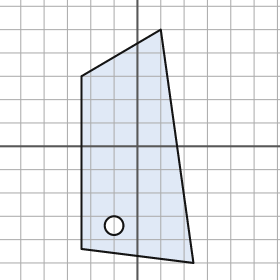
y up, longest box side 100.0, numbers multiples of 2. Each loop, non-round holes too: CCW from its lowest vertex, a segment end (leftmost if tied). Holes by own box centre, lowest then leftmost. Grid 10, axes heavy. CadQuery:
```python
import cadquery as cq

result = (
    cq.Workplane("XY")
    .moveTo(24.0, -50.0)
    .lineTo(10.0, 50.0)
    .lineTo(-24.0, 30.0)
    .lineTo(-24.0, -44.0)
    .close()
    .moveTo(-10.0, -34.0)
    .circle(4.0)
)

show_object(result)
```